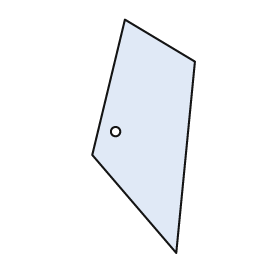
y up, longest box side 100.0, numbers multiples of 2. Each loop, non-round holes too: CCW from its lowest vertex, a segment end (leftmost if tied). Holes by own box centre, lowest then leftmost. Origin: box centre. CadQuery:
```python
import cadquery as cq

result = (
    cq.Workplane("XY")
    .moveTo(14.0, -50.0)
    .lineTo(22.0, 32.0)
    .lineTo(-8.0, 50.0)
    .lineTo(-22.0, -8.0)
    .close()
    .moveTo(-12.0, 2.0)
    .circle(2.0)
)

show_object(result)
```